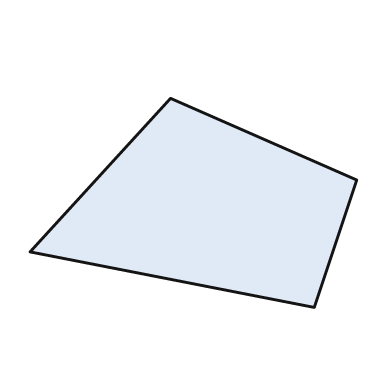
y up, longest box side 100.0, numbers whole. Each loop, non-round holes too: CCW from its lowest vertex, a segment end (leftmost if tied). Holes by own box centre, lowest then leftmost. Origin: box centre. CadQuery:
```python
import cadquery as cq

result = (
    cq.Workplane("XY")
    .moveTo(37.0, -32.0)
    .lineTo(50.0, 7.0)
    .lineTo(-7.0, 32.0)
    .lineTo(-50.0, -15.0)
    .close()
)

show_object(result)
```